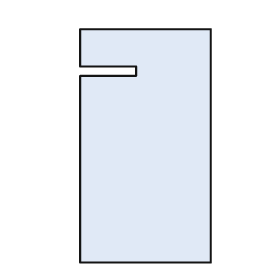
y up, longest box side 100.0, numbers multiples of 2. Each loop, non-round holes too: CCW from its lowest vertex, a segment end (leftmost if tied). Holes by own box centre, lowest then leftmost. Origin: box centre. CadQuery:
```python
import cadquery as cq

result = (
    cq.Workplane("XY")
    .moveTo(-28.0, -50.0)
    .lineTo(28.0, -50.0)
    .lineTo(28.0, 50.0)
    .lineTo(-28.0, 50.0)
    .lineTo(-28.0, 34.0)
    .lineTo(-4.0, 34.0)
    .lineTo(-4.0, 30.0)
    .lineTo(-28.0, 30.0)
    .close()
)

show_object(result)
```